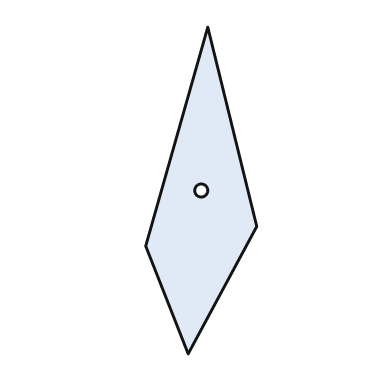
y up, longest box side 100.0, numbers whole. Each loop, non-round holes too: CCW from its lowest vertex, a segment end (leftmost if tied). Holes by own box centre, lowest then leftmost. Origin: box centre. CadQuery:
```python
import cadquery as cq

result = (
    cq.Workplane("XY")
    .moveTo(-4.0, -50.0)
    .lineTo(17.0, -11.0)
    .lineTo(2.0, 50.0)
    .lineTo(-17.0, -17.0)
    .close()
    .moveTo(0.0, 0.0)
    .circle(2.0)
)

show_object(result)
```